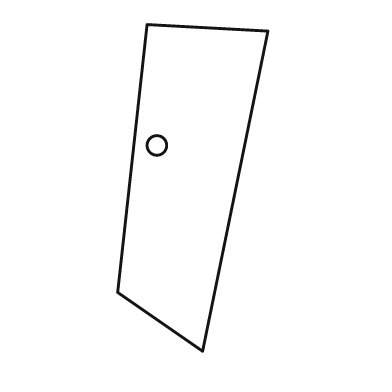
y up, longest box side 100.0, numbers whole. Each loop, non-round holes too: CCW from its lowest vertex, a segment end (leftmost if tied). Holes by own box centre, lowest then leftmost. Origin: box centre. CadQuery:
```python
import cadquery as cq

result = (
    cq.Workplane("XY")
    .moveTo(3.0, -50.0)
    .lineTo(23.0, 48.0)
    .lineTo(-14.0, 50.0)
    .lineTo(-23.0, -32.0)
    .close()
    .moveTo(-11.0, 13.0)
    .circle(3.0)
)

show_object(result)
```